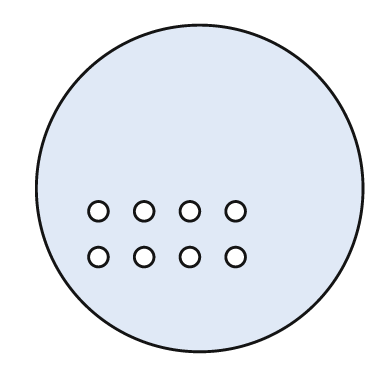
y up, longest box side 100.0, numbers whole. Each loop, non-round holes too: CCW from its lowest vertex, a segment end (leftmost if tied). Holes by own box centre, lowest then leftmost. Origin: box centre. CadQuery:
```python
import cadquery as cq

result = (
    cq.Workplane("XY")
    .moveTo(0.0, 0.0)
    .circle(50.0)
    .moveTo(-31.0, -21.0)
    .circle(3.0)
    .moveTo(-17.0, -21.0)
    .circle(3.0)
    .moveTo(-3.0, -21.0)
    .circle(3.0)
    .moveTo(11.0, -21.0)
    .circle(3.0)
    .moveTo(-31.0, -7.0)
    .circle(3.0)
    .moveTo(-17.0, -7.0)
    .circle(3.0)
    .moveTo(-3.0, -7.0)
    .circle(3.0)
    .moveTo(11.0, -7.0)
    .circle(3.0)
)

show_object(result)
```